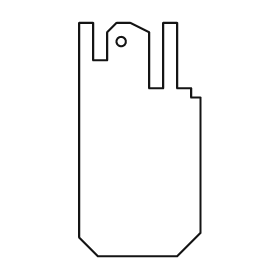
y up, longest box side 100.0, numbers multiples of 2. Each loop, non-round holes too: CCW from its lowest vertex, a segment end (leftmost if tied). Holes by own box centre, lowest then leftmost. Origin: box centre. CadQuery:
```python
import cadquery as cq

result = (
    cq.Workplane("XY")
    .moveTo(-18.0, -50.0)
    .lineTo(16.0, -50.0)
    .lineTo(26.0, -40.0)
    .lineTo(26.0, 18.0)
    .lineTo(22.0, 18.0)
    .lineTo(22.0, 22.0)
    .lineTo(16.0, 22.0)
    .lineTo(16.0, 50.0)
    .lineTo(10.0, 50.0)
    .lineTo(10.0, 22.0)
    .lineTo(4.0, 22.0)
    .lineTo(4.0, 46.0)
    .lineTo(-4.0, 50.0)
    .lineTo(-10.0, 50.0)
    .lineTo(-14.0, 46.0)
    .lineTo(-14.0, 34.0)
    .lineTo(-20.0, 34.0)
    .lineTo(-20.0, 50.0)
    .lineTo(-26.0, 50.0)
    .lineTo(-26.0, -42.0)
    .close()
    .moveTo(-8.0, 42.0)
    .circle(2.0)
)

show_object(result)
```